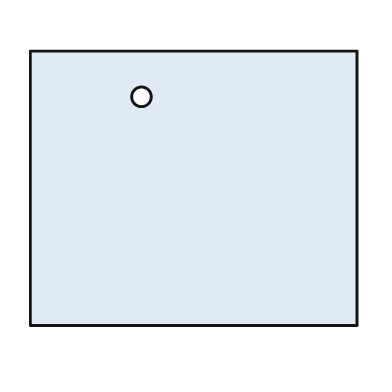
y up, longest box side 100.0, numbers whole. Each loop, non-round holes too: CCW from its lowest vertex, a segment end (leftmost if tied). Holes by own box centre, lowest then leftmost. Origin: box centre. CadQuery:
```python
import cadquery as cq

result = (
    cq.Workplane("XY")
    .moveTo(-50.0, -42.0)
    .lineTo(50.0, -42.0)
    .lineTo(50.0, 42.0)
    .lineTo(-50.0, 42.0)
    .close()
    .moveTo(-16.0, 28.0)
    .circle(3.0)
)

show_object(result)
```